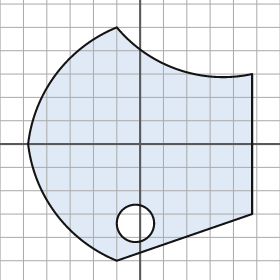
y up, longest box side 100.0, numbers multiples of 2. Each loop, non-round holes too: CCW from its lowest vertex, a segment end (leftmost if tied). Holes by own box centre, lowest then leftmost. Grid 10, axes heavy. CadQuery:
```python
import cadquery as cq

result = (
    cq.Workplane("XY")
    .moveTo(-10.0, -50.0)
    .lineTo(48.0, -30.0)
    .lineTo(48.0, 30.0)
    .threePointArc((16.0, 32.0), (-10.0, 50.0))
    .threePointArc((-36.0, 30.0), (-48.0, 0.0))
    .threePointArc((-36.0, -30.0), (-10.0, -50.0))
    .close()
    .moveTo(-2.0, -34.0)
    .circle(8.0)
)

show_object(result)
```